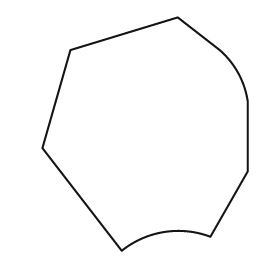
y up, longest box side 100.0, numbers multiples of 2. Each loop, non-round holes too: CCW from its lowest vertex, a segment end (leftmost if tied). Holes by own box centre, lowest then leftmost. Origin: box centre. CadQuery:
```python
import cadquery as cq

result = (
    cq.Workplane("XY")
    .moveTo(-10.0, -50.0)
    .threePointArc((8.0, -42.0), (28.0, -44.0))
    .lineTo(44.0, -16.0)
    .lineTo(44.0, 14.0)
    .threePointArc((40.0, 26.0), (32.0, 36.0))
    .lineTo(14.0, 50.0)
    .lineTo(-32.0, 36.0)
    .lineTo(-44.0, -6.0)
    .close()
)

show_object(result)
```